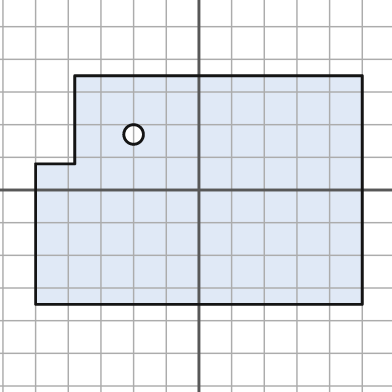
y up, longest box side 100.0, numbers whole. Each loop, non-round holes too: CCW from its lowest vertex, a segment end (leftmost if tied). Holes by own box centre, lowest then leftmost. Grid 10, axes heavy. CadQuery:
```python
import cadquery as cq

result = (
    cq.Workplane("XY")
    .moveTo(-50.0, -35.0)
    .lineTo(50.0, -35.0)
    .lineTo(50.0, 35.0)
    .lineTo(-38.0, 35.0)
    .lineTo(-38.0, 8.0)
    .lineTo(-50.0, 8.0)
    .close()
    .moveTo(-20.0, 17.0)
    .circle(3.0)
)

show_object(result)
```